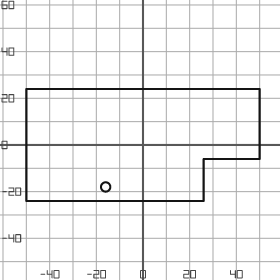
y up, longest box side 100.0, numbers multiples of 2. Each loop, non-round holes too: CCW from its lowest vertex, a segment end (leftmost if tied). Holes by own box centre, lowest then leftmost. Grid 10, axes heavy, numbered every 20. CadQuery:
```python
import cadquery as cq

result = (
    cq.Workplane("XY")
    .moveTo(-50.0, -24.0)
    .lineTo(26.0, -24.0)
    .lineTo(26.0, -6.0)
    .lineTo(50.0, -6.0)
    .lineTo(50.0, 24.0)
    .lineTo(-50.0, 24.0)
    .close()
    .moveTo(-16.0, -18.0)
    .circle(2.0)
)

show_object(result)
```